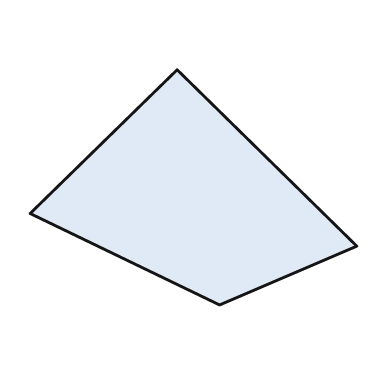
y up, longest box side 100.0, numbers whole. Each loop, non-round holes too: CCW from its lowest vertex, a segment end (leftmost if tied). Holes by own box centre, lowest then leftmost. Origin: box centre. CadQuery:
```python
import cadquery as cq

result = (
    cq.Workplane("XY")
    .moveTo(8.0, -36.0)
    .lineTo(50.0, -18.0)
    .lineTo(-5.0, 36.0)
    .lineTo(-50.0, -8.0)
    .close()
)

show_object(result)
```